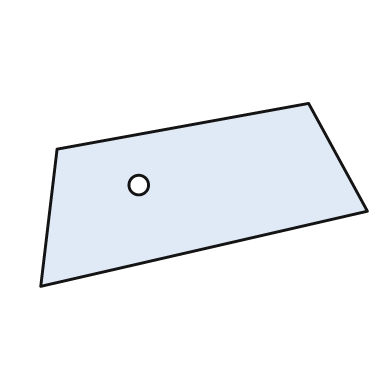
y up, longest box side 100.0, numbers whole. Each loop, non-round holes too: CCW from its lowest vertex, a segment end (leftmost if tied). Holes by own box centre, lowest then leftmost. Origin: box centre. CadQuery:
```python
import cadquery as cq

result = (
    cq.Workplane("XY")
    .moveTo(-50.0, -28.0)
    .lineTo(50.0, -5.0)
    .lineTo(32.0, 28.0)
    .lineTo(-45.0, 14.0)
    .close()
    .moveTo(-20.0, 3.0)
    .circle(3.0)
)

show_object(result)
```